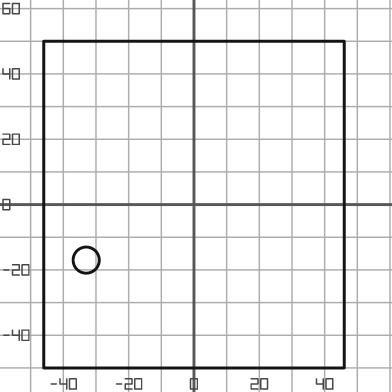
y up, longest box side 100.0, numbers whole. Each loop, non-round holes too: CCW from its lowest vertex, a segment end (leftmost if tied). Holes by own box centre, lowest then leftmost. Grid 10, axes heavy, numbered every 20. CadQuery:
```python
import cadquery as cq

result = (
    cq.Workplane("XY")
    .moveTo(-46.0, -50.0)
    .lineTo(46.0, -50.0)
    .lineTo(46.0, 50.0)
    .lineTo(-46.0, 50.0)
    .close()
    .moveTo(-33.0, -17.0)
    .circle(4.0)
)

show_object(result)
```